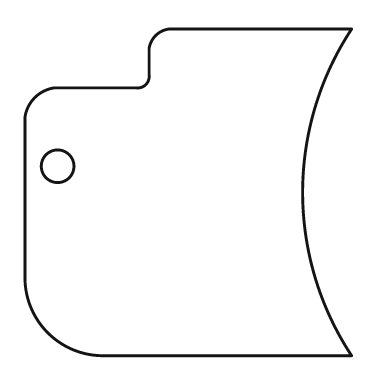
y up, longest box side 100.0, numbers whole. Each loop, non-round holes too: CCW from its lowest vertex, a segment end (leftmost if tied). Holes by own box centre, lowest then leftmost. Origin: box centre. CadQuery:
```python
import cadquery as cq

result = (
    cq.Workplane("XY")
    .moveTo(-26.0, -50.0)
    .lineTo(50.0, -50.0)
    .threePointArc((35.0, 0.0), (50.0, 50.0))
    .lineTo(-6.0, 50.0)
    .threePointArc((-10.0, 48.0), (-12.0, 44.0))
    .lineTo(-12.0, 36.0)
    .threePointArc((-13.0, 33.0), (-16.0, 32.0))
    .lineTo(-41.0, 32.0)
    .threePointArc((-47.0, 29.0), (-50.0, 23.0))
    .lineTo(-50.0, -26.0)
    .threePointArc((-43.0, -43.0), (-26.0, -50.0))
    .close()
    .moveTo(-40.0, 8.0)
    .circle(5.0)
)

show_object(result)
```